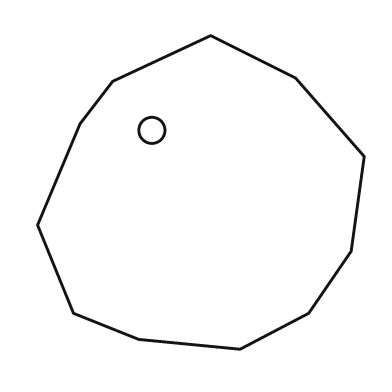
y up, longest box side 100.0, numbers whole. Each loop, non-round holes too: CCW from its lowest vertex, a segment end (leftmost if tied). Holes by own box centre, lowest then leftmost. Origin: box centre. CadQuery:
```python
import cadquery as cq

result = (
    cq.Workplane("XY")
    .moveTo(12.0, -48.0)
    .lineTo(33.0, -37.0)
    .lineTo(46.0, -18.0)
    .lineTo(50.0, 11.0)
    .lineTo(29.0, 35.0)
    .lineTo(3.0, 48.0)
    .lineTo(-27.0, 34.0)
    .lineTo(-37.0, 21.0)
    .lineTo(-50.0, -10.0)
    .lineTo(-39.0, -37.0)
    .lineTo(-19.0, -45.0)
    .close()
    .moveTo(-15.0, 19.0)
    .circle(4.0)
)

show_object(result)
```